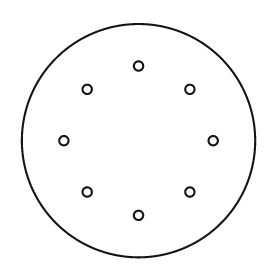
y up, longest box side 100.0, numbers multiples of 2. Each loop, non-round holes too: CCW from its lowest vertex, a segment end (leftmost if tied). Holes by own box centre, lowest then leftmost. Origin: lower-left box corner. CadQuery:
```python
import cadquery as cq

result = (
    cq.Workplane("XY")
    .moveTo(50.0, 50.0)
    .circle(50.0)
    .moveTo(50.0, 18.0)
    .circle(2.0)
    .moveTo(28.0, 28.0)
    .circle(2.0)
    .moveTo(72.0, 28.0)
    .circle(2.0)
    .moveTo(18.0, 50.0)
    .circle(2.0)
    .moveTo(82.0, 50.0)
    .circle(2.0)
    .moveTo(28.0, 72.0)
    .circle(2.0)
    .moveTo(72.0, 72.0)
    .circle(2.0)
    .moveTo(50.0, 82.0)
    .circle(2.0)
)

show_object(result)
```